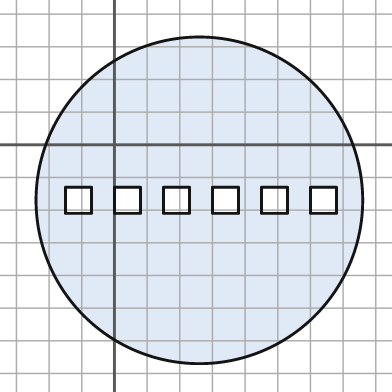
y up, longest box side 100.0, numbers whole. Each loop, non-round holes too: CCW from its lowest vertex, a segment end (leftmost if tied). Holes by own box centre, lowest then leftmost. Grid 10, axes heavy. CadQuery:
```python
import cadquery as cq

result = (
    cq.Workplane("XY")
    .moveTo(26.0, -17.0)
    .circle(50.0)
    .moveTo(-15.0, -21.0)
    .lineTo(-7.0, -21.0)
    .lineTo(-7.0, -13.0)
    .lineTo(-15.0, -13.0)
    .close()
    .moveTo(0.0, -21.0)
    .lineTo(8.0, -21.0)
    .lineTo(8.0, -13.0)
    .lineTo(0.0, -13.0)
    .close()
    .moveTo(15.0, -21.0)
    .lineTo(23.0, -21.0)
    .lineTo(23.0, -13.0)
    .lineTo(15.0, -13.0)
    .close()
    .moveTo(30.0, -21.0)
    .lineTo(38.0, -21.0)
    .lineTo(38.0, -13.0)
    .lineTo(30.0, -13.0)
    .close()
    .moveTo(45.0, -21.0)
    .lineTo(53.0, -21.0)
    .lineTo(53.0, -13.0)
    .lineTo(45.0, -13.0)
    .close()
    .moveTo(60.0, -21.0)
    .lineTo(68.0, -21.0)
    .lineTo(68.0, -13.0)
    .lineTo(60.0, -13.0)
    .close()
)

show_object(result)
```